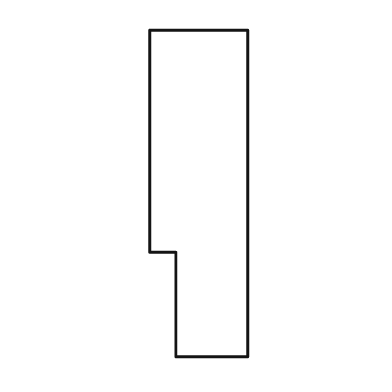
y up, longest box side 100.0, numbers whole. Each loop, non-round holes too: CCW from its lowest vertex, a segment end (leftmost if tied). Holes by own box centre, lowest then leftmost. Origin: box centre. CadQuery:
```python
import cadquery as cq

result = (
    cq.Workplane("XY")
    .moveTo(-7.0, -50.0)
    .lineTo(15.0, -50.0)
    .lineTo(15.0, 50.0)
    .lineTo(-15.0, 50.0)
    .lineTo(-15.0, -18.0)
    .lineTo(-7.0, -18.0)
    .close()
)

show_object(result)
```